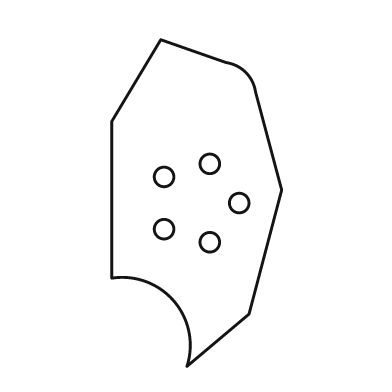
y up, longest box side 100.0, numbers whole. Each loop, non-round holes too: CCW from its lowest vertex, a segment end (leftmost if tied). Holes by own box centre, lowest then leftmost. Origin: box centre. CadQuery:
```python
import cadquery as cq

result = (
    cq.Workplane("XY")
    .moveTo(-3.0, -50.0)
    .lineTo(16.0, -34.0)
    .lineTo(26.0, 4.0)
    .lineTo(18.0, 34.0)
    .threePointArc((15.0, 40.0), (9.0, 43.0))
    .lineTo(-11.0, 50.0)
    .lineTo(-26.0, 25.0)
    .lineTo(-26.0, -23.0)
    .threePointArc((-7.0, -30.0), (-3.0, -50.0))
    .close()
    .moveTo(4.0, -12.0)
    .circle(3.0)
    .moveTo(-10.0, -8.0)
    .circle(3.0)
    .moveTo(13.0, 0.0)
    .circle(3.0)
    .moveTo(-10.0, 8.0)
    .circle(3.0)
    .moveTo(4.0, 12.0)
    .circle(3.0)
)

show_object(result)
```